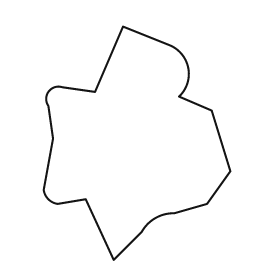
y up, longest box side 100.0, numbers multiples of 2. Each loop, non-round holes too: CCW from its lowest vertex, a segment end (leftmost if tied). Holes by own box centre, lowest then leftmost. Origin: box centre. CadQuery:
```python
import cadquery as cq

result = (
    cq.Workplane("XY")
    .moveTo(-10.0, -50.0)
    .lineTo(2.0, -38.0)
    .threePointArc((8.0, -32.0), (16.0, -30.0))
    .lineTo(30.0, -26.0)
    .lineTo(40.0, -12.0)
    .lineTo(32.0, 14.0)
    .lineTo(18.0, 20.0)
    .threePointArc((22.0, 32.0), (14.0, 42.0))
    .lineTo(-6.0, 50.0)
    .lineTo(-18.0, 22.0)
    .lineTo(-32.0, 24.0)
    .threePointArc((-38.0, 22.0), (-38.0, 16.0))
    .lineTo(-36.0, 2.0)
    .lineTo(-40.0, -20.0)
    .threePointArc((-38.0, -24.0), (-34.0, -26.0))
    .lineTo(-22.0, -24.0)
    .close()
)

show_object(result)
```